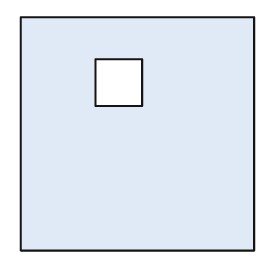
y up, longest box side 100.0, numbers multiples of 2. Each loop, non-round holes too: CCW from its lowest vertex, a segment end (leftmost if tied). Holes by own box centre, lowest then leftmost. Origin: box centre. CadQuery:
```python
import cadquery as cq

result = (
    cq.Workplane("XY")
    .moveTo(-50.0, -50.0)
    .lineTo(50.0, -50.0)
    .lineTo(50.0, 50.0)
    .lineTo(-50.0, 50.0)
    .close()
    .moveTo(-18.0, 12.0)
    .lineTo(2.0, 12.0)
    .lineTo(2.0, 32.0)
    .lineTo(-18.0, 32.0)
    .close()
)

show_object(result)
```